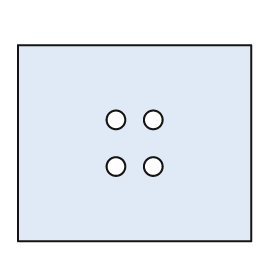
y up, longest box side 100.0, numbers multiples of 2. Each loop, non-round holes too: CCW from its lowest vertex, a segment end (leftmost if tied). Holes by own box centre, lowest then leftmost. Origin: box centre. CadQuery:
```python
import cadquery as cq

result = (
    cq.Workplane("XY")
    .moveTo(-50.0, -42.0)
    .lineTo(50.0, -42.0)
    .lineTo(50.0, 42.0)
    .lineTo(-50.0, 42.0)
    .close()
    .moveTo(-8.0, -10.0)
    .circle(4.0)
    .moveTo(8.0, -10.0)
    .circle(4.0)
    .moveTo(-8.0, 10.0)
    .circle(4.0)
    .moveTo(8.0, 10.0)
    .circle(4.0)
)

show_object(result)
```